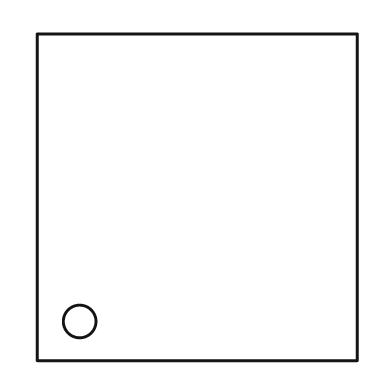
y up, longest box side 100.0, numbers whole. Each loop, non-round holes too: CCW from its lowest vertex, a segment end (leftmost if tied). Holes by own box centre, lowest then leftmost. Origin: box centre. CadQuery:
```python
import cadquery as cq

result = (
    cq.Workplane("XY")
    .moveTo(-49.0, -50.0)
    .lineTo(49.0, -50.0)
    .lineTo(49.0, 50.0)
    .lineTo(-49.0, 50.0)
    .close()
    .moveTo(-36.0, -38.0)
    .circle(5.0)
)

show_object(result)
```